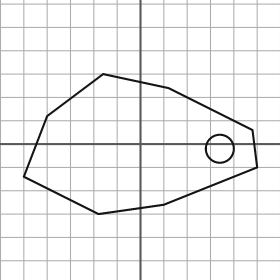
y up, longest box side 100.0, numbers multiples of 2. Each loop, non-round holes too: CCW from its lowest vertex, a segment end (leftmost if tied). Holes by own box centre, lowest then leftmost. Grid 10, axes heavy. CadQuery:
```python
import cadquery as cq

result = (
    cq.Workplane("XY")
    .moveTo(-18.0, -30.0)
    .lineTo(10.0, -26.0)
    .lineTo(50.0, -10.0)
    .lineTo(48.0, 6.0)
    .lineTo(12.0, 24.0)
    .lineTo(-16.0, 30.0)
    .lineTo(-40.0, 12.0)
    .lineTo(-50.0, -14.0)
    .close()
    .moveTo(34.0, -2.0)
    .circle(6.0)
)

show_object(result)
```